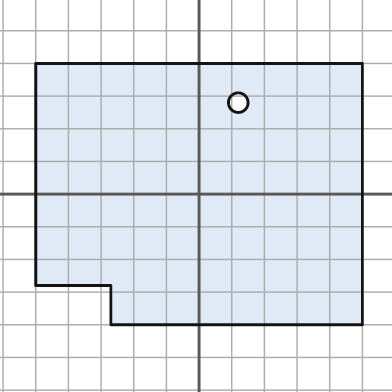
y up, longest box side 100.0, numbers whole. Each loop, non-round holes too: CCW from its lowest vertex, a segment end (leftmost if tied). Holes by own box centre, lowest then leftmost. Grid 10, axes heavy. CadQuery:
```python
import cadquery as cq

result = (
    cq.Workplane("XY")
    .moveTo(-27.0, -40.0)
    .lineTo(50.0, -40.0)
    .lineTo(50.0, 40.0)
    .lineTo(-50.0, 40.0)
    .lineTo(-50.0, -28.0)
    .lineTo(-27.0, -28.0)
    .close()
    .moveTo(12.0, 28.0)
    .circle(3.0)
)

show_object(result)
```